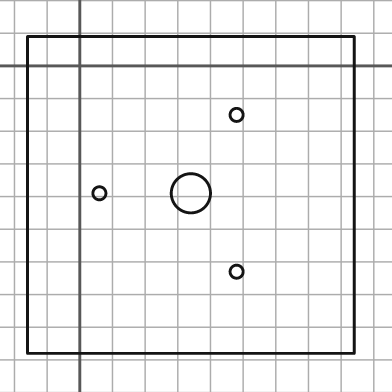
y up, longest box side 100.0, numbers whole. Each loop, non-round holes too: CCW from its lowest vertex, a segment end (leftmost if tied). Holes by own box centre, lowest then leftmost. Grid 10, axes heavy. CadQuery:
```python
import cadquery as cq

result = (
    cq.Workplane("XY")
    .moveTo(-16.0, -88.0)
    .lineTo(84.0, -88.0)
    .lineTo(84.0, 9.0)
    .lineTo(-16.0, 9.0)
    .close()
    .moveTo(48.0, -63.0)
    .circle(2.0)
    .moveTo(6.0, -39.0)
    .circle(2.0)
    .moveTo(34.0, -39.0)
    .circle(6.0)
    .moveTo(48.0, -15.0)
    .circle(2.0)
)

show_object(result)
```